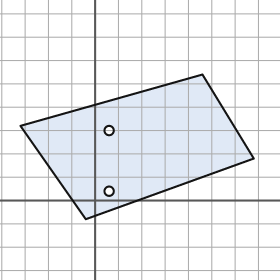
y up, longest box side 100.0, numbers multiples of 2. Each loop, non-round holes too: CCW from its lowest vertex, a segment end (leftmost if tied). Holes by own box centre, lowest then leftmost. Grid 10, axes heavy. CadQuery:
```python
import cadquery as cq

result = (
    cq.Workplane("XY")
    .moveTo(-4.0, -8.0)
    .lineTo(68.0, 18.0)
    .lineTo(46.0, 54.0)
    .lineTo(-32.0, 32.0)
    .close()
    .moveTo(6.0, 4.0)
    .circle(2.0)
    .moveTo(6.0, 30.0)
    .circle(2.0)
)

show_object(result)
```